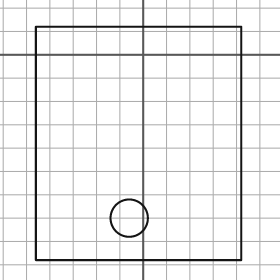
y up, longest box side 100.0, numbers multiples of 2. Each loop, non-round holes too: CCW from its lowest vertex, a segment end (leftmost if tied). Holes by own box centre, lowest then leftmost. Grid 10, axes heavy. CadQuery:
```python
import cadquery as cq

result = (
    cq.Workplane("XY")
    .moveTo(-46.0, -88.0)
    .lineTo(42.0, -88.0)
    .lineTo(42.0, 12.0)
    .lineTo(-46.0, 12.0)
    .close()
    .moveTo(-6.0, -70.0)
    .circle(8.0)
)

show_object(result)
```